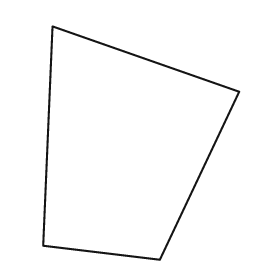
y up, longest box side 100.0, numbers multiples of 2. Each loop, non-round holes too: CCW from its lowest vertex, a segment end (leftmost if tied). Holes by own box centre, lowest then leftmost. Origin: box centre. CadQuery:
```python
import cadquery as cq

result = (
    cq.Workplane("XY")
    .moveTo(8.0, -50.0)
    .lineTo(42.0, 22.0)
    .lineTo(-38.0, 50.0)
    .lineTo(-42.0, -44.0)
    .close()
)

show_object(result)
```